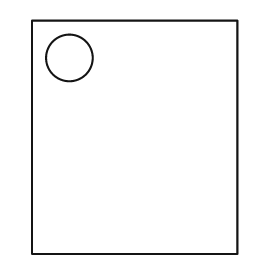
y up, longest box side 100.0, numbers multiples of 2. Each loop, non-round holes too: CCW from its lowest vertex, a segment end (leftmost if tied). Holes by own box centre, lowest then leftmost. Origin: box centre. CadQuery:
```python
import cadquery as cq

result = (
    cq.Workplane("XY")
    .moveTo(-44.0, -50.0)
    .lineTo(44.0, -50.0)
    .lineTo(44.0, 50.0)
    .lineTo(-44.0, 50.0)
    .close()
    .moveTo(-28.0, 34.0)
    .circle(10.0)
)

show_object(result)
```